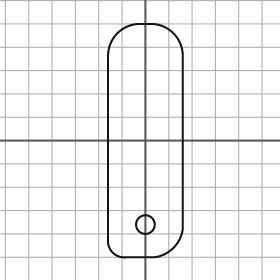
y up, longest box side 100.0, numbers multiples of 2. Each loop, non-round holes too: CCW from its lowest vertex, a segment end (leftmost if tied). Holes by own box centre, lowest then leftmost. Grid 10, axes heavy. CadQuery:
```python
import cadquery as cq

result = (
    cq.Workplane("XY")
    .moveTo(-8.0, -50.0)
    .lineTo(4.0, -50.0)
    .threePointArc((12.0, -46.0), (16.0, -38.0))
    .lineTo(16.0, 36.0)
    .threePointArc((12.0, 46.0), (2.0, 50.0))
    .lineTo(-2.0, 50.0)
    .threePointArc((-12.0, 46.0), (-16.0, 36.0))
    .lineTo(-16.0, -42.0)
    .threePointArc((-14.0, -48.0), (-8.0, -50.0))
    .close()
    .moveTo(0.0, -36.0)
    .circle(4.0)
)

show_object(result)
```